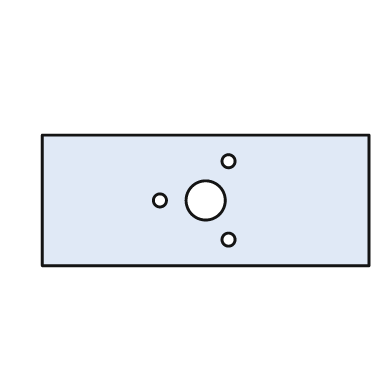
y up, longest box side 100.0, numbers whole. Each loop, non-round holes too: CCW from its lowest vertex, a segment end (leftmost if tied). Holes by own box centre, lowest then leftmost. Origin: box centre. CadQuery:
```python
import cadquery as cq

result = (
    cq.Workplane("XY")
    .moveTo(-50.0, -20.0)
    .lineTo(50.0, -20.0)
    .lineTo(50.0, 20.0)
    .lineTo(-50.0, 20.0)
    .close()
    .moveTo(7.0, -12.0)
    .circle(2.0)
    .moveTo(-14.0, 0.0)
    .circle(2.0)
    .moveTo(0.0, 0.0)
    .circle(6.0)
    .moveTo(7.0, 12.0)
    .circle(2.0)
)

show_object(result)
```